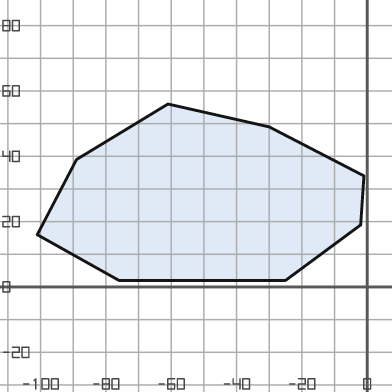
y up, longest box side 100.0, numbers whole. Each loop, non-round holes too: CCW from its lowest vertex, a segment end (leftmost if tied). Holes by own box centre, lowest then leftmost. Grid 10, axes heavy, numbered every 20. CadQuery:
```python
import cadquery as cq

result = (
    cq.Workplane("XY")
    .moveTo(-76.0, 2.0)
    .lineTo(-25.0, 2.0)
    .lineTo(-2.0, 19.0)
    .lineTo(-1.0, 34.0)
    .lineTo(-30.0, 49.0)
    .lineTo(-61.0, 56.0)
    .lineTo(-89.0, 39.0)
    .lineTo(-101.0, 16.0)
    .close()
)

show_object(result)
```